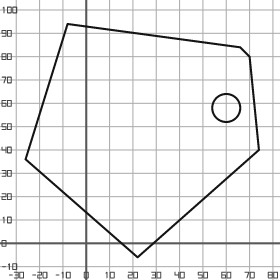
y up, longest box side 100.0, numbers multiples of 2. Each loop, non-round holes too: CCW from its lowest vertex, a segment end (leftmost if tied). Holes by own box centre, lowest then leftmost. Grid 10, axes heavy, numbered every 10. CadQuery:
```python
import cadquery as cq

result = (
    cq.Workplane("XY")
    .moveTo(22.0, -6.0)
    .lineTo(74.0, 40.0)
    .lineTo(70.0, 80.0)
    .lineTo(66.0, 84.0)
    .lineTo(-8.0, 94.0)
    .lineTo(-26.0, 36.0)
    .close()
    .moveTo(60.0, 58.0)
    .circle(6.0)
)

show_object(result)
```